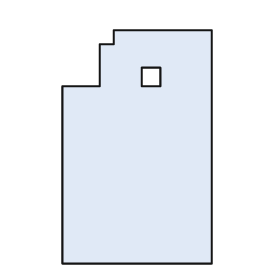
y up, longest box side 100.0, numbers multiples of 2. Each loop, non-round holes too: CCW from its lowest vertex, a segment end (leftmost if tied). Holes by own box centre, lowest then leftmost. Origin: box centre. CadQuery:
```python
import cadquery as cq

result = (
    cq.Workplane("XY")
    .moveTo(-32.0, -50.0)
    .lineTo(32.0, -50.0)
    .lineTo(32.0, 50.0)
    .lineTo(-10.0, 50.0)
    .lineTo(-10.0, 44.0)
    .lineTo(-16.0, 44.0)
    .lineTo(-16.0, 26.0)
    .lineTo(-32.0, 26.0)
    .close()
    .moveTo(2.0, 26.0)
    .lineTo(10.0, 26.0)
    .lineTo(10.0, 34.0)
    .lineTo(2.0, 34.0)
    .close()
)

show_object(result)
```